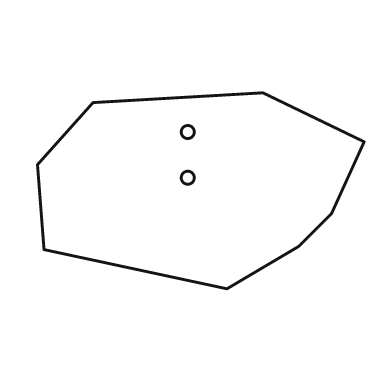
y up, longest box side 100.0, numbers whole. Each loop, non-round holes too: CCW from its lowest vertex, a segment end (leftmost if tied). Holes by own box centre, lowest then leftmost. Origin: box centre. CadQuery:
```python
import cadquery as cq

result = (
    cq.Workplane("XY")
    .moveTo(8.0, -30.0)
    .lineTo(30.0, -17.0)
    .lineTo(40.0, -7.0)
    .lineTo(50.0, 15.0)
    .lineTo(19.0, 30.0)
    .lineTo(-33.0, 27.0)
    .lineTo(-50.0, 8.0)
    .lineTo(-48.0, -18.0)
    .close()
    .moveTo(-4.0, 4.0)
    .circle(2.0)
    .moveTo(-4.0, 18.0)
    .circle(2.0)
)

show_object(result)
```